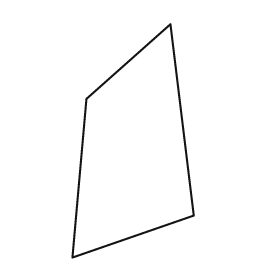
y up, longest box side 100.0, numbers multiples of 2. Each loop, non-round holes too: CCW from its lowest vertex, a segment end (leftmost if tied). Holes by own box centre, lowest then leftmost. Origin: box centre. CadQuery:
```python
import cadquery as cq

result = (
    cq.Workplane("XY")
    .moveTo(-26.0, -50.0)
    .lineTo(26.0, -32.0)
    .lineTo(16.0, 50.0)
    .lineTo(-20.0, 18.0)
    .close()
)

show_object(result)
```